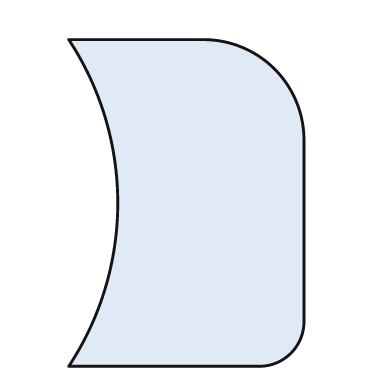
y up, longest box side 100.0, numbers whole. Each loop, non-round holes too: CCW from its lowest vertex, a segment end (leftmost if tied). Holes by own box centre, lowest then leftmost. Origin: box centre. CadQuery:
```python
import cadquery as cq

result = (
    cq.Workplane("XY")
    .moveTo(-36.0, -50.0)
    .lineTo(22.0, -50.0)
    .threePointArc((32.0, -46.0), (36.0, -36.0))
    .lineTo(36.0, 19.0)
    .threePointArc((27.0, 41.0), (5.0, 50.0))
    .lineTo(-36.0, 50.0)
    .threePointArc((-21.0, 0.0), (-36.0, -50.0))
    .close()
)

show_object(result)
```